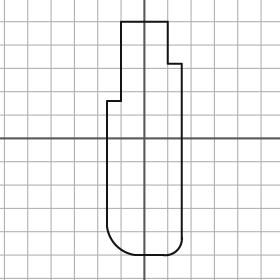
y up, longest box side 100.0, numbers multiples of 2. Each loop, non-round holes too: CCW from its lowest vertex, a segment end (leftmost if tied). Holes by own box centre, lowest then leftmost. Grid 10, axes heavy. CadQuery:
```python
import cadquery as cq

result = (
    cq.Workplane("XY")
    .moveTo(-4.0, -50.0)
    .lineTo(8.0, -50.0)
    .threePointArc((14.0, -48.0), (16.0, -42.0))
    .lineTo(16.0, 32.0)
    .lineTo(10.0, 32.0)
    .lineTo(10.0, 50.0)
    .lineTo(-10.0, 50.0)
    .lineTo(-10.0, 16.0)
    .lineTo(-16.0, 16.0)
    .lineTo(-16.0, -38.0)
    .threePointArc((-12.0, -46.0), (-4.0, -50.0))
    .close()
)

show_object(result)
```